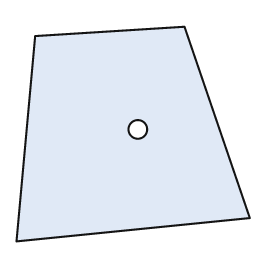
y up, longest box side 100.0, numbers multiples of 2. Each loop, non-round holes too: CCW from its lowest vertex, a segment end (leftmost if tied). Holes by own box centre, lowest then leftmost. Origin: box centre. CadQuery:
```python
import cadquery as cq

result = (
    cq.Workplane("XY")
    .moveTo(-50.0, -46.0)
    .lineTo(50.0, -36.0)
    .lineTo(22.0, 46.0)
    .lineTo(-42.0, 42.0)
    .close()
    .moveTo(2.0, 2.0)
    .circle(4.0)
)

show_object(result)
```